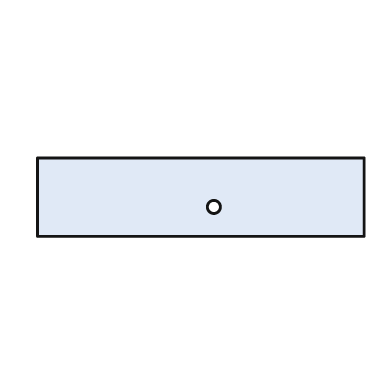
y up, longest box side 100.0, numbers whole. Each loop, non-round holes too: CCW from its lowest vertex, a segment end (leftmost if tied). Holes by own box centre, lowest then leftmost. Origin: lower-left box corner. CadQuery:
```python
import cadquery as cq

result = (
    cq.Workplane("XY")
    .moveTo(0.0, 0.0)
    .lineTo(100.0, 0.0)
    .lineTo(100.0, 24.0)
    .lineTo(0.0, 24.0)
    .close()
    .moveTo(54.0, 9.0)
    .circle(2.0)
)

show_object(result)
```